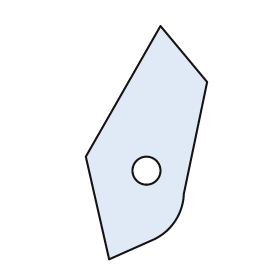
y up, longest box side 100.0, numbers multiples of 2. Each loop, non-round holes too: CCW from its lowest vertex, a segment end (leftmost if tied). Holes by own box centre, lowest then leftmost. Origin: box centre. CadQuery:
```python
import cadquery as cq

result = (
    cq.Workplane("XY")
    .moveTo(-16.0, -50.0)
    .lineTo(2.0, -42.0)
    .threePointArc((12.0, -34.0), (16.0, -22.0))
    .lineTo(26.0, 26.0)
    .lineTo(6.0, 50.0)
    .lineTo(-26.0, -6.0)
    .close()
    .moveTo(0.0, -12.0)
    .circle(6.0)
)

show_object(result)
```